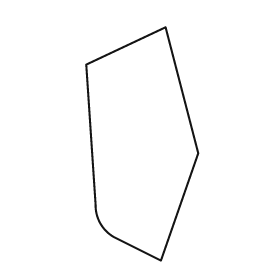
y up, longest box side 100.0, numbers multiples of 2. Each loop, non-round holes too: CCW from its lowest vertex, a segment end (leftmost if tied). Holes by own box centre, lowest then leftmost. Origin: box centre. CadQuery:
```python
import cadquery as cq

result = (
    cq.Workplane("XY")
    .moveTo(8.0, -50.0)
    .lineTo(24.0, -4.0)
    .lineTo(10.0, 50.0)
    .lineTo(-24.0, 34.0)
    .lineTo(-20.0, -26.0)
    .threePointArc((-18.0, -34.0), (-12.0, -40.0))
    .close()
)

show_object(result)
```